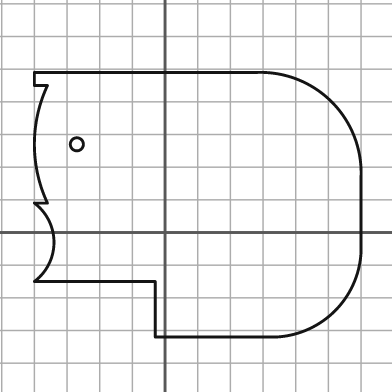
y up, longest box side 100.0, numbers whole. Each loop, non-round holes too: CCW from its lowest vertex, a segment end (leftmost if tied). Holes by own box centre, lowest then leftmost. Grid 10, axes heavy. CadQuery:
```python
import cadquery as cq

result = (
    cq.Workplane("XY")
    .moveTo(-3.0, -32.0)
    .lineTo(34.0, -32.0)
    .threePointArc((52.0, -24.0), (60.0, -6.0))
    .lineTo(60.0, 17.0)
    .threePointArc((51.0, 40.0), (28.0, 49.0))
    .lineTo(-40.0, 49.0)
    .lineTo(-40.0, 45.0)
    .lineTo(-36.0, 45.0)
    .threePointArc((-40.0, 27.0), (-36.0, 9.0))
    .lineTo(-40.0, 9.0)
    .threePointArc((-34.0, -3.0), (-40.0, -15.0))
    .lineTo(-3.0, -15.0)
    .close()
    .moveTo(-27.0, 27.0)
    .circle(2.0)
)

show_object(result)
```